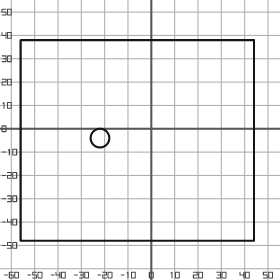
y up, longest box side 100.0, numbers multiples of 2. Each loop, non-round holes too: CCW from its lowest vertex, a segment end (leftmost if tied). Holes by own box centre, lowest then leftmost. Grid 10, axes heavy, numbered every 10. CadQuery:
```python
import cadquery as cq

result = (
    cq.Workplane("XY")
    .moveTo(-56.0, -48.0)
    .lineTo(44.0, -48.0)
    .lineTo(44.0, 38.0)
    .lineTo(-56.0, 38.0)
    .close()
    .moveTo(-22.0, -4.0)
    .circle(4.0)
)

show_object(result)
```